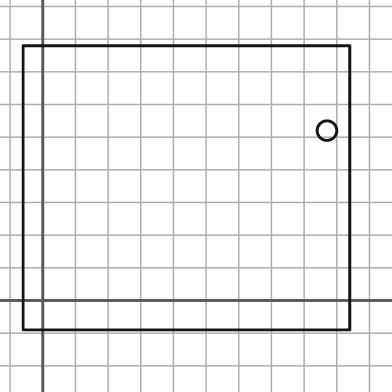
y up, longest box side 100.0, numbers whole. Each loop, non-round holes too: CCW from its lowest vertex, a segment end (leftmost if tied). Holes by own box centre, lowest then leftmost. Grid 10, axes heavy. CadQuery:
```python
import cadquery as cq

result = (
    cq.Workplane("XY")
    .moveTo(-6.0, -9.0)
    .lineTo(94.0, -9.0)
    .lineTo(94.0, 78.0)
    .lineTo(-6.0, 78.0)
    .close()
    .moveTo(87.0, 52.0)
    .circle(3.0)
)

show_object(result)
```